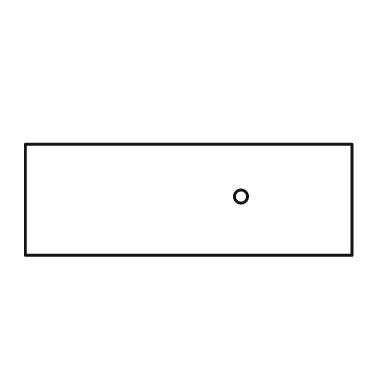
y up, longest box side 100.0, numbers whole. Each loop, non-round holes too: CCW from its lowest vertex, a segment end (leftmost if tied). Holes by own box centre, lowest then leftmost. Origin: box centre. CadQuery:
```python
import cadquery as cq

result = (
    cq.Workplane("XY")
    .moveTo(-50.0, -17.0)
    .lineTo(50.0, -17.0)
    .lineTo(50.0, 17.0)
    .lineTo(-50.0, 17.0)
    .close()
    .moveTo(16.0, 1.0)
    .circle(2.0)
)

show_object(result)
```